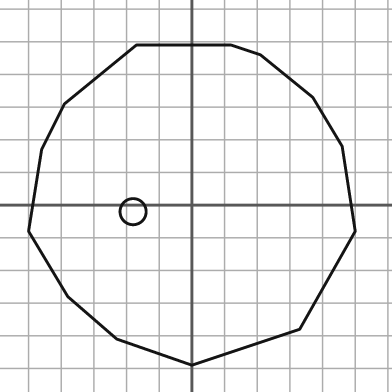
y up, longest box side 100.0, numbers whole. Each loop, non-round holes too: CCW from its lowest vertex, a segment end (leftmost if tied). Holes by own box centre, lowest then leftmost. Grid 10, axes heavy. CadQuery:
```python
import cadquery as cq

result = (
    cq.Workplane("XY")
    .moveTo(0.0, -49.0)
    .lineTo(33.0, -38.0)
    .lineTo(50.0, -8.0)
    .lineTo(46.0, 18.0)
    .lineTo(37.0, 33.0)
    .lineTo(21.0, 46.0)
    .lineTo(12.0, 49.0)
    .lineTo(-17.0, 49.0)
    .lineTo(-39.0, 31.0)
    .lineTo(-46.0, 17.0)
    .lineTo(-50.0, -8.0)
    .lineTo(-38.0, -28.0)
    .lineTo(-23.0, -41.0)
    .close()
    .moveTo(-18.0, -2.0)
    .circle(4.0)
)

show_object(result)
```